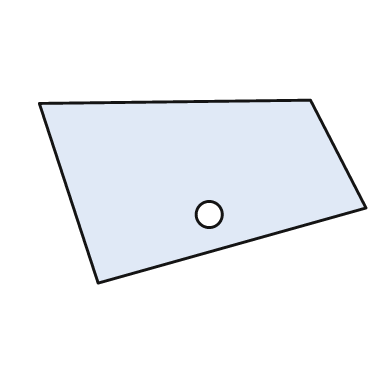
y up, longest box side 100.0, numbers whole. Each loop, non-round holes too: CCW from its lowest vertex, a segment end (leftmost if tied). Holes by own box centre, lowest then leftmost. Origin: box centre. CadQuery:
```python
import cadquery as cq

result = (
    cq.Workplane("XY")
    .moveTo(-32.0, -28.0)
    .lineTo(50.0, -5.0)
    .lineTo(33.0, 28.0)
    .lineTo(-50.0, 27.0)
    .close()
    .moveTo(2.0, -7.0)
    .circle(4.0)
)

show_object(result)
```